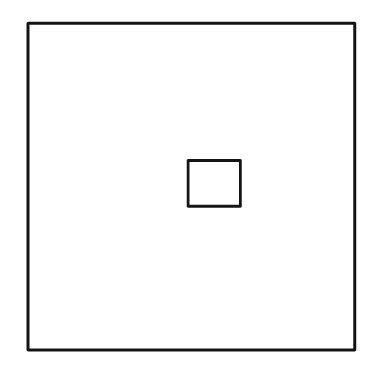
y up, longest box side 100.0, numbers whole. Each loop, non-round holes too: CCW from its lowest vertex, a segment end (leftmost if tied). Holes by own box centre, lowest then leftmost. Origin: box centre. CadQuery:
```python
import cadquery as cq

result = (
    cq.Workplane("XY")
    .moveTo(-50.0, -50.0)
    .lineTo(50.0, -50.0)
    .lineTo(50.0, 50.0)
    .lineTo(-50.0, 50.0)
    .close()
    .moveTo(-1.0, -6.0)
    .lineTo(15.0, -6.0)
    .lineTo(15.0, 8.0)
    .lineTo(-1.0, 8.0)
    .close()
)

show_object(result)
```